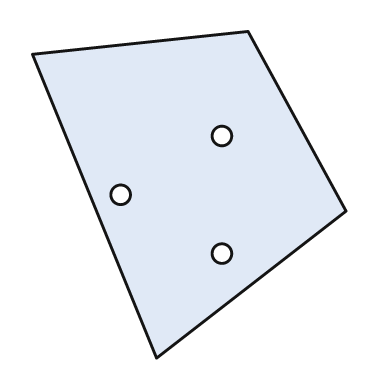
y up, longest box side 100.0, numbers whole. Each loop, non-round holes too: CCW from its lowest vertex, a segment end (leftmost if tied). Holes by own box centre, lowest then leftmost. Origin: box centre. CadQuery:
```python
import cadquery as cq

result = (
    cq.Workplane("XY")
    .moveTo(-10.0, -50.0)
    .lineTo(48.0, -5.0)
    .lineTo(18.0, 50.0)
    .lineTo(-48.0, 43.0)
    .close()
    .moveTo(10.0, -18.0)
    .circle(3.0)
    .moveTo(-21.0, 0.0)
    .circle(3.0)
    .moveTo(10.0, 18.0)
    .circle(3.0)
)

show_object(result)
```